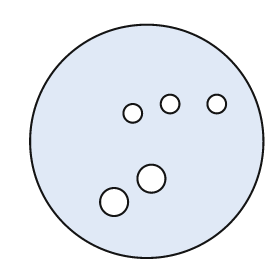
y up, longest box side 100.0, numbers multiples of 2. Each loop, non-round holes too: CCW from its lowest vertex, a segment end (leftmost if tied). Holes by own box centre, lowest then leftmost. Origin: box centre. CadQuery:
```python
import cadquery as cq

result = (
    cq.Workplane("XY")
    .moveTo(0.0, 0.0)
    .circle(50.0)
    .moveTo(-14.0, -26.0)
    .circle(6.0)
    .moveTo(2.0, -16.0)
    .circle(6.0)
    .moveTo(-6.0, 12.0)
    .circle(4.0)
    .moveTo(10.0, 16.0)
    .circle(4.0)
    .moveTo(30.0, 16.0)
    .circle(4.0)
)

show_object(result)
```